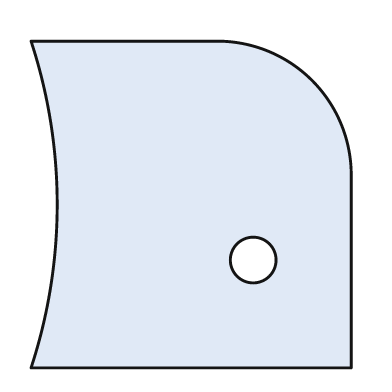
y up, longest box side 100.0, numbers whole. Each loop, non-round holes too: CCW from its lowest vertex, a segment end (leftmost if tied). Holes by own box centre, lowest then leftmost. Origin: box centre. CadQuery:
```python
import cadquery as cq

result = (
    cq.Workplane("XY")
    .moveTo(-49.0, -50.0)
    .lineTo(49.0, -50.0)
    .lineTo(49.0, 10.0)
    .threePointArc((37.0, 38.0), (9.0, 50.0))
    .lineTo(-49.0, 50.0)
    .threePointArc((-41.0, 0.0), (-49.0, -50.0))
    .close()
    .moveTo(19.0, -17.0)
    .circle(7.0)
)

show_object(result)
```